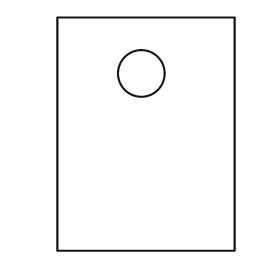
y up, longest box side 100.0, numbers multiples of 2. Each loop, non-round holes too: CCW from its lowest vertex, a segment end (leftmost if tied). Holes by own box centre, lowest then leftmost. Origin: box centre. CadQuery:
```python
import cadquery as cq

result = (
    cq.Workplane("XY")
    .moveTo(-38.0, -50.0)
    .lineTo(38.0, -50.0)
    .lineTo(38.0, 50.0)
    .lineTo(-38.0, 50.0)
    .close()
    .moveTo(-2.0, 26.0)
    .circle(10.0)
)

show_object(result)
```